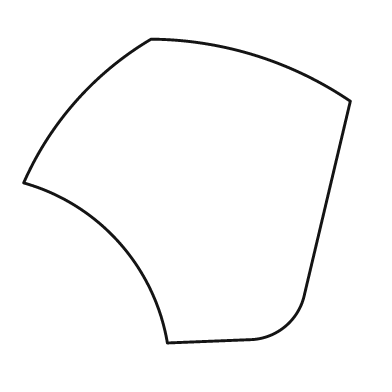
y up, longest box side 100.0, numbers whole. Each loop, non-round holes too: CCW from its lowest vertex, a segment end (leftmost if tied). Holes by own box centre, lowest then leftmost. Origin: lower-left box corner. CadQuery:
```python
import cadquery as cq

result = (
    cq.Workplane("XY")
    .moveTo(44.0, 0.0)
    .lineTo(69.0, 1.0)
    .threePointArc((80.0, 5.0), (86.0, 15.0))
    .lineTo(100.0, 74.0)
    .threePointArc((71.0, 88.0), (39.0, 93.0))
    .threePointArc((16.0, 74.0), (0.0, 49.0))
    .threePointArc((29.0, 31.0), (44.0, 0.0))
    .close()
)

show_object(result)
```